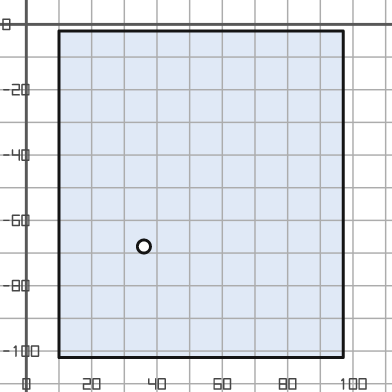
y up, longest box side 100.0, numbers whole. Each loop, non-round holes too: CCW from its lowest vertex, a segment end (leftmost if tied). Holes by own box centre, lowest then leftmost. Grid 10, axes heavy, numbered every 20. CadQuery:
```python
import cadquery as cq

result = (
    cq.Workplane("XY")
    .moveTo(10.0, -102.0)
    .lineTo(97.0, -102.0)
    .lineTo(97.0, -2.0)
    .lineTo(10.0, -2.0)
    .close()
    .moveTo(36.0, -68.0)
    .circle(2.0)
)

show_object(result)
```